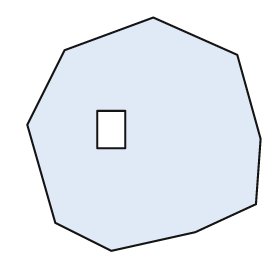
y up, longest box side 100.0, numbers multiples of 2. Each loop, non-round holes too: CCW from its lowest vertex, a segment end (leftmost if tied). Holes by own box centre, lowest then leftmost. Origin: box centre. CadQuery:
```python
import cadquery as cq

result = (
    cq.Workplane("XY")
    .moveTo(-14.0, -50.0)
    .lineTo(22.0, -42.0)
    .lineTo(48.0, -30.0)
    .lineTo(50.0, -2.0)
    .lineTo(40.0, 34.0)
    .lineTo(4.0, 50.0)
    .lineTo(-34.0, 36.0)
    .lineTo(-50.0, 4.0)
    .lineTo(-38.0, -38.0)
    .close()
    .moveTo(-20.0, -6.0)
    .lineTo(-8.0, -6.0)
    .lineTo(-8.0, 10.0)
    .lineTo(-20.0, 10.0)
    .close()
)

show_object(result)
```